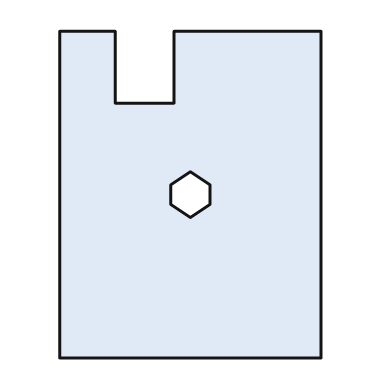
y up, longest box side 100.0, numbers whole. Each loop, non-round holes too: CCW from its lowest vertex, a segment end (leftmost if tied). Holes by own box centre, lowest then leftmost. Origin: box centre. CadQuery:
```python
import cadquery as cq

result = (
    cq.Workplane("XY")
    .moveTo(-40.0, -50.0)
    .lineTo(40.0, -50.0)
    .lineTo(40.0, 50.0)
    .lineTo(-5.0, 50.0)
    .lineTo(-5.0, 28.0)
    .lineTo(-23.0, 28.0)
    .lineTo(-23.0, 50.0)
    .lineTo(-40.0, 50.0)
    .close()
    .moveTo(0.0, -7.0)
    .lineTo(6.0, -3.0)
    .lineTo(6.0, 3.0)
    .lineTo(0.0, 7.0)
    .lineTo(-6.0, 3.0)
    .lineTo(-6.0, -3.0)
    .close()
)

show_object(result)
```